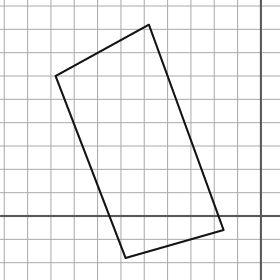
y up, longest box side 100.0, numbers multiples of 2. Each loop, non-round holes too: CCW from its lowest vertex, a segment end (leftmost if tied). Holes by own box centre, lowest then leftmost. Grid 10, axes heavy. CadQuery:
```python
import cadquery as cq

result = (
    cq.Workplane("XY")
    .moveTo(-58.0, -18.0)
    .lineTo(-16.0, -6.0)
    .lineTo(-48.0, 82.0)
    .lineTo(-88.0, 60.0)
    .close()
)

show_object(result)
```